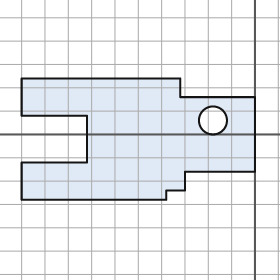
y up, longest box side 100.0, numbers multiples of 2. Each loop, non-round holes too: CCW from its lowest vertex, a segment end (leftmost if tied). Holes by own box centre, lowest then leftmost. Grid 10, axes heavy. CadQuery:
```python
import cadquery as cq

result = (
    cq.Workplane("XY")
    .moveTo(-100.0, -28.0)
    .lineTo(-38.0, -28.0)
    .lineTo(-38.0, -24.0)
    .lineTo(-30.0, -24.0)
    .lineTo(-30.0, -16.0)
    .lineTo(0.0, -16.0)
    .lineTo(0.0, 16.0)
    .lineTo(-32.0, 16.0)
    .lineTo(-32.0, 24.0)
    .lineTo(-100.0, 24.0)
    .lineTo(-100.0, 8.0)
    .lineTo(-72.0, 8.0)
    .lineTo(-72.0, -12.0)
    .lineTo(-100.0, -12.0)
    .close()
    .moveTo(-18.0, 6.0)
    .circle(6.0)
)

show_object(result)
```